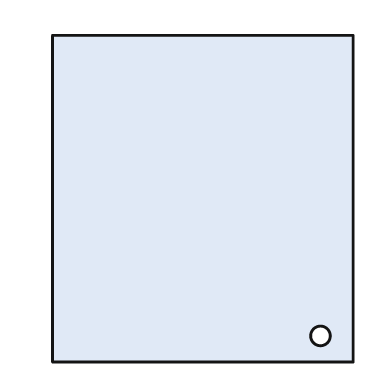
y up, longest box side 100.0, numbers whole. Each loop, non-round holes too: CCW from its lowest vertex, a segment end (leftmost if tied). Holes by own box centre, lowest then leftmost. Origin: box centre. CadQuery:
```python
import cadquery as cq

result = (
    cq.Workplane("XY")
    .moveTo(-46.0, -50.0)
    .lineTo(46.0, -50.0)
    .lineTo(46.0, 50.0)
    .lineTo(-46.0, 50.0)
    .close()
    .moveTo(36.0, -42.0)
    .circle(3.0)
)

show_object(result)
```